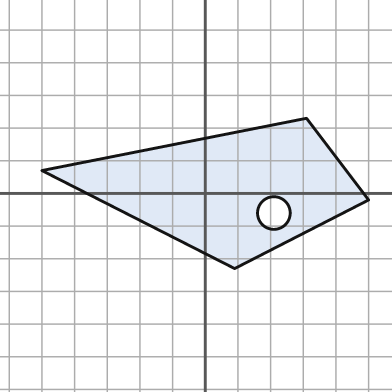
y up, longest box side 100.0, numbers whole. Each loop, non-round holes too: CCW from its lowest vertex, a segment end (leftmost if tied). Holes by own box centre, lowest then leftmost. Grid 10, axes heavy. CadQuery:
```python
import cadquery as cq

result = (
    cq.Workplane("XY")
    .moveTo(9.0, -23.0)
    .lineTo(50.0, -2.0)
    .lineTo(31.0, 23.0)
    .lineTo(-50.0, 7.0)
    .close()
    .moveTo(21.0, -6.0)
    .circle(5.0)
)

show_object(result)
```